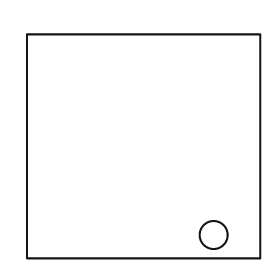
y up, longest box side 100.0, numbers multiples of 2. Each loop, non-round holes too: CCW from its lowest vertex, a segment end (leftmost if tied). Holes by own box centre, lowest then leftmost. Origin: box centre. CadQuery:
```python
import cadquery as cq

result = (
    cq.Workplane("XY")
    .moveTo(-50.0, -48.0)
    .lineTo(50.0, -48.0)
    .lineTo(50.0, 48.0)
    .lineTo(-50.0, 48.0)
    .close()
    .moveTo(30.0, -38.0)
    .circle(6.0)
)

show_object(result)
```